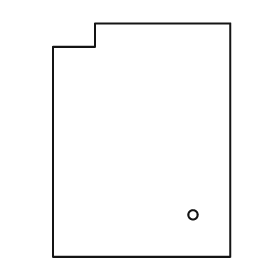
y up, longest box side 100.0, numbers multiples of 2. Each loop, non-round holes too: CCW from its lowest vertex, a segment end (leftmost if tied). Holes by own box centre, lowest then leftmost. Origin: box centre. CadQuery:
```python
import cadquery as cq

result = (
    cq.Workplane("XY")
    .moveTo(-38.0, -50.0)
    .lineTo(38.0, -50.0)
    .lineTo(38.0, 50.0)
    .lineTo(-20.0, 50.0)
    .lineTo(-20.0, 40.0)
    .lineTo(-38.0, 40.0)
    .close()
    .moveTo(22.0, -32.0)
    .circle(2.0)
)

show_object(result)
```